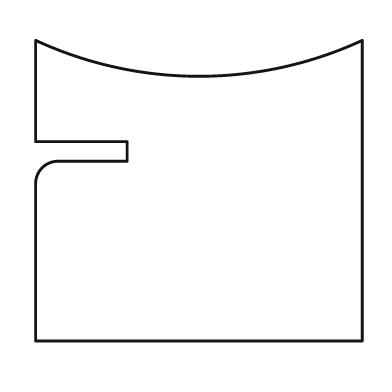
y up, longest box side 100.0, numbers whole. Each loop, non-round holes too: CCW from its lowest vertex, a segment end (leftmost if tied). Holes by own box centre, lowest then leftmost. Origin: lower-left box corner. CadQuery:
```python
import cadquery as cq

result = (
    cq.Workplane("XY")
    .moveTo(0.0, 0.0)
    .lineTo(100.0, 0.0)
    .lineTo(100.0, 92.0)
    .threePointArc((50.0, 81.0), (0.0, 92.0))
    .lineTo(0.0, 61.0)
    .lineTo(28.0, 61.0)
    .lineTo(28.0, 55.0)
    .lineTo(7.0, 55.0)
    .threePointArc((2.0, 53.0), (0.0, 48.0))
    .close()
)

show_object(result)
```